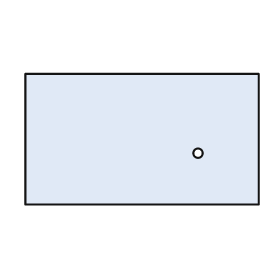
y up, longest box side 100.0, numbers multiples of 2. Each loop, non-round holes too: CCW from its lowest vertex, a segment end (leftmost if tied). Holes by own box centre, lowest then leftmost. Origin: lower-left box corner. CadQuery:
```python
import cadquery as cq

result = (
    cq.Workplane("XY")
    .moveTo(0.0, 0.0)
    .lineTo(100.0, 0.0)
    .lineTo(100.0, 56.0)
    .lineTo(0.0, 56.0)
    .close()
    .moveTo(74.0, 22.0)
    .circle(2.0)
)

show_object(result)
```